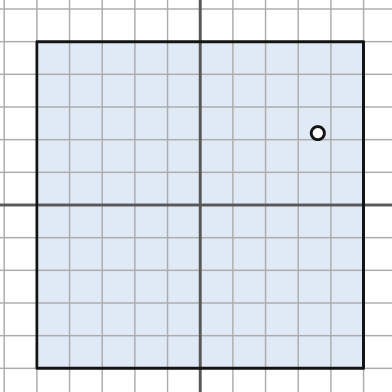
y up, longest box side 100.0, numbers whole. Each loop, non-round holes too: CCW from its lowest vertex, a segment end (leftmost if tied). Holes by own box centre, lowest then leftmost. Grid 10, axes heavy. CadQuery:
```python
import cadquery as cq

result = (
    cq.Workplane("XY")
    .moveTo(-50.0, -50.0)
    .lineTo(50.0, -50.0)
    .lineTo(50.0, 50.0)
    .lineTo(-50.0, 50.0)
    .close()
    .moveTo(36.0, 22.0)
    .circle(2.0)
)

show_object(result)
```